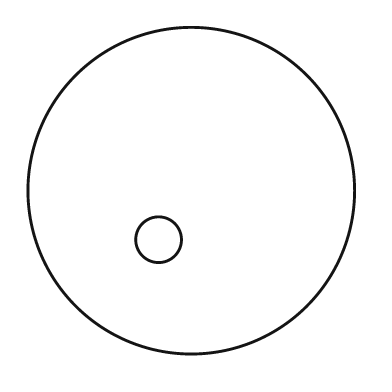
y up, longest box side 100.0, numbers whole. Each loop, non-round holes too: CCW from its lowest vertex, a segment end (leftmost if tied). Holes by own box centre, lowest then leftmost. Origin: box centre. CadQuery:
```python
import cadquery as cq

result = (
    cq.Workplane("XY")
    .moveTo(0.0, 0.0)
    .circle(50.0)
    .moveTo(-10.0, -15.0)
    .circle(7.0)
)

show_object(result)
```